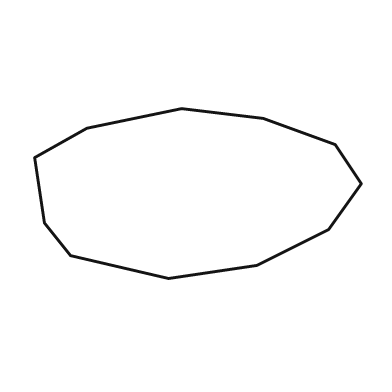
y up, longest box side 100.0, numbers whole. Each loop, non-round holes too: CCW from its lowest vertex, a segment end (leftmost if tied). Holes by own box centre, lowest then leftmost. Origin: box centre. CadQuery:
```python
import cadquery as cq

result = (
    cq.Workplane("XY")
    .moveTo(-9.0, -26.0)
    .lineTo(18.0, -22.0)
    .lineTo(40.0, -11.0)
    .lineTo(50.0, 3.0)
    .lineTo(42.0, 15.0)
    .lineTo(20.0, 23.0)
    .lineTo(-5.0, 26.0)
    .lineTo(-34.0, 20.0)
    .lineTo(-50.0, 11.0)
    .lineTo(-47.0, -9.0)
    .lineTo(-39.0, -19.0)
    .close()
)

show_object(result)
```